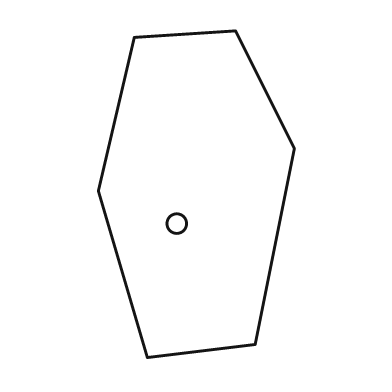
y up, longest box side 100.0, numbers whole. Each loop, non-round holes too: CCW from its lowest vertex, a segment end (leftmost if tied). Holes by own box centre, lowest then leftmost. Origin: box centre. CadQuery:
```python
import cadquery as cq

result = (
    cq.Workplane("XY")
    .moveTo(-15.0, -50.0)
    .lineTo(18.0, -46.0)
    .lineTo(30.0, 14.0)
    .lineTo(12.0, 50.0)
    .lineTo(-19.0, 48.0)
    .lineTo(-30.0, 1.0)
    .close()
    .moveTo(-6.0, -9.0)
    .circle(3.0)
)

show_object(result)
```